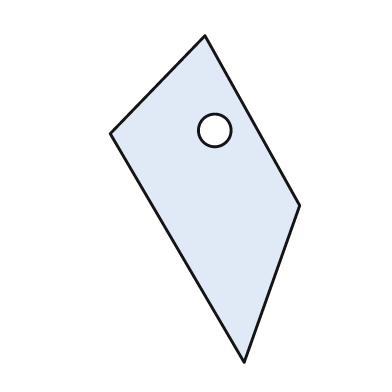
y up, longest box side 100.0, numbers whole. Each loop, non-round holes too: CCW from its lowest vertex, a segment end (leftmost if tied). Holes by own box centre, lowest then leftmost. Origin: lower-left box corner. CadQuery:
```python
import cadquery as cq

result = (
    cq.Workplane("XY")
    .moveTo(41.0, 0.0)
    .lineTo(58.0, 48.0)
    .lineTo(29.0, 100.0)
    .lineTo(0.0, 70.0)
    .close()
    .moveTo(32.0, 71.0)
    .circle(5.0)
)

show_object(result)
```